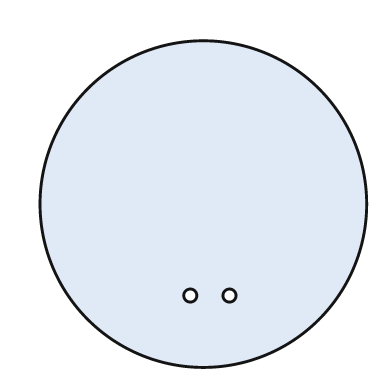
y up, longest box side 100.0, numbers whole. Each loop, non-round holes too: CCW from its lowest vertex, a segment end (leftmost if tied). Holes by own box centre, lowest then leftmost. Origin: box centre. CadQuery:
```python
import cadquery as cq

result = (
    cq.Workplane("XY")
    .moveTo(0.0, 0.0)
    .circle(50.0)
    .moveTo(-4.0, -28.0)
    .circle(2.0)
    .moveTo(8.0, -28.0)
    .circle(2.0)
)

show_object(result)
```